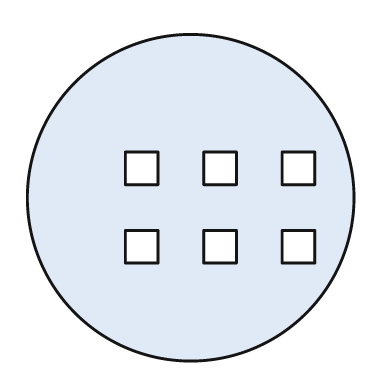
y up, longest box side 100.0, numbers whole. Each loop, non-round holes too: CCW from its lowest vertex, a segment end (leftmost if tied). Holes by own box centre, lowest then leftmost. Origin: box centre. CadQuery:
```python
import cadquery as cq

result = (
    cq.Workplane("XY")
    .moveTo(0.0, 0.0)
    .circle(50.0)
    .moveTo(-20.0, -20.0)
    .lineTo(-10.0, -20.0)
    .lineTo(-10.0, -10.0)
    .lineTo(-20.0, -10.0)
    .close()
    .moveTo(4.0, -20.0)
    .lineTo(14.0, -20.0)
    .lineTo(14.0, -10.0)
    .lineTo(4.0, -10.0)
    .close()
    .moveTo(28.0, -20.0)
    .lineTo(38.0, -20.0)
    .lineTo(38.0, -10.0)
    .lineTo(28.0, -10.0)
    .close()
    .moveTo(-20.0, 4.0)
    .lineTo(-10.0, 4.0)
    .lineTo(-10.0, 14.0)
    .lineTo(-20.0, 14.0)
    .close()
    .moveTo(4.0, 4.0)
    .lineTo(14.0, 4.0)
    .lineTo(14.0, 14.0)
    .lineTo(4.0, 14.0)
    .close()
    .moveTo(28.0, 4.0)
    .lineTo(38.0, 4.0)
    .lineTo(38.0, 14.0)
    .lineTo(28.0, 14.0)
    .close()
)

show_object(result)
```